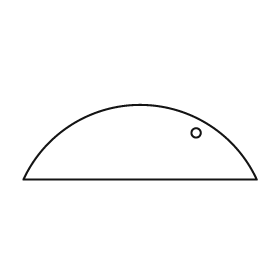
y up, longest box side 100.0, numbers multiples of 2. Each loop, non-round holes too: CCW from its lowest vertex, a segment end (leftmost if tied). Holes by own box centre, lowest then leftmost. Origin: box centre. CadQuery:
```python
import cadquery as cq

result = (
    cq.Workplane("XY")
    .moveTo(-50.0, -16.0)
    .lineTo(50.0, -16.0)
    .threePointArc((0.0, 16.0), (-50.0, -16.0))
    .close()
    .moveTo(24.0, 4.0)
    .circle(2.0)
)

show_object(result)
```